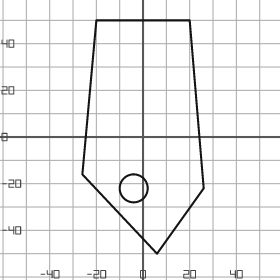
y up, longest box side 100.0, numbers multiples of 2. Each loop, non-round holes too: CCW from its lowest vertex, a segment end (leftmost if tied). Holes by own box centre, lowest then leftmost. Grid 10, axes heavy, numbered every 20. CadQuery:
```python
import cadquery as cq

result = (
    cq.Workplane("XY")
    .moveTo(6.0, -50.0)
    .lineTo(26.0, -22.0)
    .lineTo(20.0, 50.0)
    .lineTo(-20.0, 50.0)
    .lineTo(-26.0, -16.0)
    .close()
    .moveTo(-4.0, -22.0)
    .circle(6.0)
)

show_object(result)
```